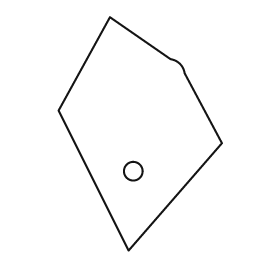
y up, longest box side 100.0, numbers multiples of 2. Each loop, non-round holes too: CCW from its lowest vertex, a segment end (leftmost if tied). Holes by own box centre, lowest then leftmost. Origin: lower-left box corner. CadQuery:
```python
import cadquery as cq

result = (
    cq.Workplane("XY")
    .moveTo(30.0, 0.0)
    .lineTo(70.0, 46.0)
    .lineTo(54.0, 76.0)
    .threePointArc((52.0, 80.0), (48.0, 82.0))
    .lineTo(22.0, 100.0)
    .lineTo(0.0, 60.0)
    .close()
    .moveTo(32.0, 34.0)
    .circle(4.0)
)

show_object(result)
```